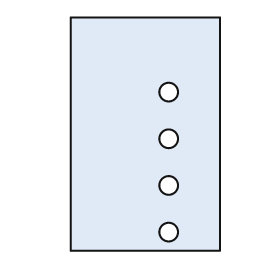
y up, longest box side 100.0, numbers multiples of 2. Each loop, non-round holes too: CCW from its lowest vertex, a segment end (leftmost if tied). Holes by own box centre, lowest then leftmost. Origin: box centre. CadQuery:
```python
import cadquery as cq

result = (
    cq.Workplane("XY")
    .moveTo(-32.0, -50.0)
    .lineTo(32.0, -50.0)
    .lineTo(32.0, 50.0)
    .lineTo(-32.0, 50.0)
    .close()
    .moveTo(10.0, -42.0)
    .circle(4.0)
    .moveTo(10.0, -22.0)
    .circle(4.0)
    .moveTo(10.0, -2.0)
    .circle(4.0)
    .moveTo(10.0, 18.0)
    .circle(4.0)
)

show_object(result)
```